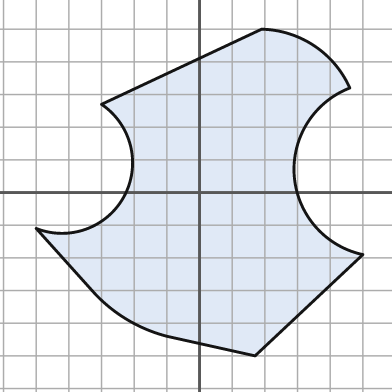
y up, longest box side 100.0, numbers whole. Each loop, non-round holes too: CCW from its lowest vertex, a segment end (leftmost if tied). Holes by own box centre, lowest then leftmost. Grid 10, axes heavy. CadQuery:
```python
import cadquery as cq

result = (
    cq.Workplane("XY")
    .moveTo(17.0, -50.0)
    .lineTo(50.0, -19.0)
    .threePointArc((29.0, 5.0), (46.0, 32.0))
    .threePointArc((35.0, 45.0), (19.0, 50.0))
    .lineTo(-30.0, 27.0)
    .threePointArc((-23.0, -1.0), (-50.0, -11.0))
    .lineTo(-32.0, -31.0)
    .threePointArc((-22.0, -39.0), (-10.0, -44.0))
    .close()
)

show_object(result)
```